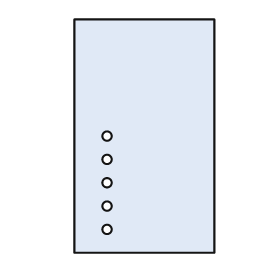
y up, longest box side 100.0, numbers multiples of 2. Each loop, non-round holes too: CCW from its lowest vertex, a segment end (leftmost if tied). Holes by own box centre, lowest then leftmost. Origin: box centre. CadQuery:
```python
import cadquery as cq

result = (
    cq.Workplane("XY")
    .moveTo(-30.0, -50.0)
    .lineTo(30.0, -50.0)
    .lineTo(30.0, 50.0)
    .lineTo(-30.0, 50.0)
    .close()
    .moveTo(-16.0, -40.0)
    .circle(2.0)
    .moveTo(-16.0, -30.0)
    .circle(2.0)
    .moveTo(-16.0, -20.0)
    .circle(2.0)
    .moveTo(-16.0, -10.0)
    .circle(2.0)
    .moveTo(-16.0, 0.0)
    .circle(2.0)
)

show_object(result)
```